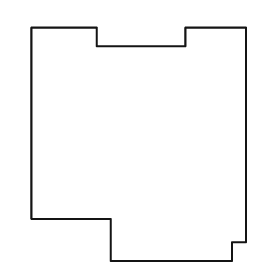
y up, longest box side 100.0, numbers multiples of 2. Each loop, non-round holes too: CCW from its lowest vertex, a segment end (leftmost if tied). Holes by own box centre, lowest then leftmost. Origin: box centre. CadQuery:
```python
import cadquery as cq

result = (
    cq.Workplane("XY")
    .moveTo(-12.0, -50.0)
    .lineTo(40.0, -50.0)
    .lineTo(40.0, -42.0)
    .lineTo(46.0, -42.0)
    .lineTo(46.0, 50.0)
    .lineTo(20.0, 50.0)
    .lineTo(20.0, 42.0)
    .lineTo(-18.0, 42.0)
    .lineTo(-18.0, 50.0)
    .lineTo(-46.0, 50.0)
    .lineTo(-46.0, -32.0)
    .lineTo(-12.0, -32.0)
    .close()
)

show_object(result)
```